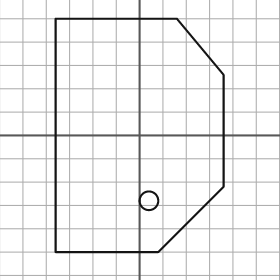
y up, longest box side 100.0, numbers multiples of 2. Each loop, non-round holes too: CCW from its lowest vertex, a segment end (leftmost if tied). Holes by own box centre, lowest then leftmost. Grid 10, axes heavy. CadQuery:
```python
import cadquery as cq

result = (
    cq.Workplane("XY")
    .moveTo(-36.0, -50.0)
    .lineTo(8.0, -50.0)
    .lineTo(36.0, -22.0)
    .lineTo(36.0, 26.0)
    .lineTo(16.0, 50.0)
    .lineTo(-36.0, 50.0)
    .close()
    .moveTo(4.0, -28.0)
    .circle(4.0)
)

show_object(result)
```